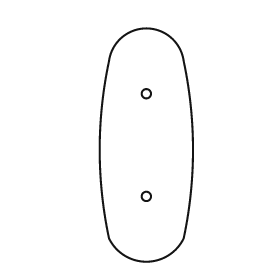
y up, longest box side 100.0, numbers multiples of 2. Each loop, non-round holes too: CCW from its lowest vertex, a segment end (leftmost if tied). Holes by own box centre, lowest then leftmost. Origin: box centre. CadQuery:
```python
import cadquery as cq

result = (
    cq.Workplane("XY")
    .moveTo(-16.0, -40.0)
    .threePointArc((0.0, -50.0), (16.0, -40.0))
    .threePointArc((20.0, -2.0), (16.0, 36.0))
    .threePointArc((0.0, 50.0), (-16.0, 36.0))
    .threePointArc((-20.0, -2.0), (-16.0, -40.0))
    .close()
    .moveTo(0.0, -22.0)
    .circle(2.0)
    .moveTo(0.0, 22.0)
    .circle(2.0)
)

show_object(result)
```